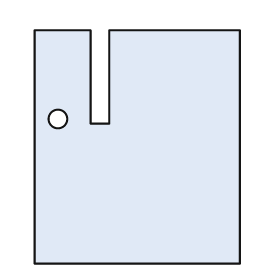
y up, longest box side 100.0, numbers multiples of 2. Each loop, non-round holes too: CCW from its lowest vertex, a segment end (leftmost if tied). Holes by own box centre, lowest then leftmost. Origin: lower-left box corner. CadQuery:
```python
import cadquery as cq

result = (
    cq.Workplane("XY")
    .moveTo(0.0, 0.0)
    .lineTo(88.0, 0.0)
    .lineTo(88.0, 100.0)
    .lineTo(32.0, 100.0)
    .lineTo(32.0, 60.0)
    .lineTo(24.0, 60.0)
    .lineTo(24.0, 100.0)
    .lineTo(0.0, 100.0)
    .close()
    .moveTo(10.0, 62.0)
    .circle(4.0)
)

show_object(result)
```